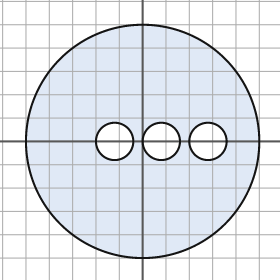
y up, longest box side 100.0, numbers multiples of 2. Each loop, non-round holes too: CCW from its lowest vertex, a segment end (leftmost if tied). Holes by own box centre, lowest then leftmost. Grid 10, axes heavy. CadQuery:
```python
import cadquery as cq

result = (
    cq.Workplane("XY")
    .moveTo(0.0, 0.0)
    .circle(50.0)
    .moveTo(-12.0, 0.0)
    .circle(8.0)
    .moveTo(8.0, 0.0)
    .circle(8.0)
    .moveTo(28.0, 0.0)
    .circle(8.0)
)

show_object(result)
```